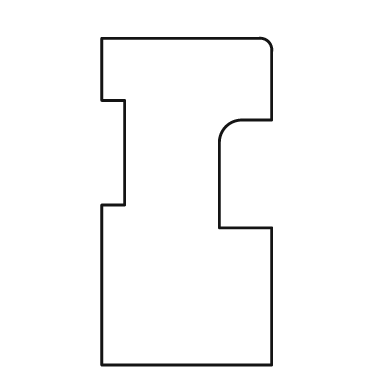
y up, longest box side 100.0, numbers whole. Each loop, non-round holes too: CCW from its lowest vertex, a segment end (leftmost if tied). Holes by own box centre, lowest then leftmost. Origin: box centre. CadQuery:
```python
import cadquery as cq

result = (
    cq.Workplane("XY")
    .moveTo(-26.0, -50.0)
    .lineTo(26.0, -50.0)
    .lineTo(26.0, -8.0)
    .lineTo(10.0, -8.0)
    .lineTo(10.0, 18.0)
    .threePointArc((12.0, 23.0), (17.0, 25.0))
    .lineTo(26.0, 25.0)
    .lineTo(26.0, 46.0)
    .threePointArc((25.0, 49.0), (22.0, 50.0))
    .lineTo(-26.0, 50.0)
    .lineTo(-26.0, 31.0)
    .lineTo(-19.0, 31.0)
    .lineTo(-19.0, -1.0)
    .lineTo(-26.0, -1.0)
    .close()
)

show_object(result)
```